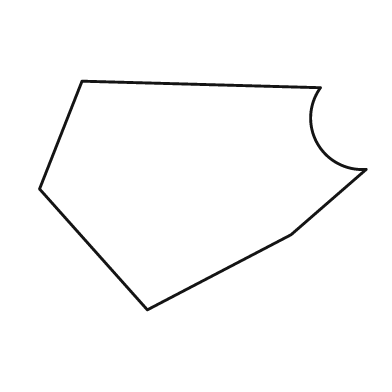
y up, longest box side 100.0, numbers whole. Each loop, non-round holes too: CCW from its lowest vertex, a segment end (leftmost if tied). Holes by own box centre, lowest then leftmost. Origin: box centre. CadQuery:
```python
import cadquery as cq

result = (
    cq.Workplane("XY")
    .moveTo(-17.0, -35.0)
    .lineTo(27.0, -12.0)
    .lineTo(50.0, 8.0)
    .threePointArc((35.0, 16.0), (36.0, 33.0))
    .lineTo(-37.0, 35.0)
    .lineTo(-50.0, 2.0)
    .close()
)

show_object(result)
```